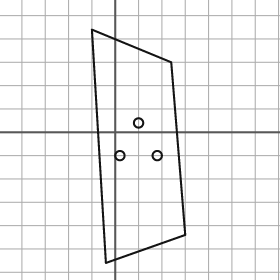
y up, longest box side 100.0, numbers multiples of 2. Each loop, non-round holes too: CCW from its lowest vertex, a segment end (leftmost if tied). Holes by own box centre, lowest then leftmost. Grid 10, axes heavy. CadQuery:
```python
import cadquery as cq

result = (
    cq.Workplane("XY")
    .moveTo(-4.0, -56.0)
    .lineTo(30.0, -44.0)
    .lineTo(24.0, 30.0)
    .lineTo(-10.0, 44.0)
    .close()
    .moveTo(2.0, -10.0)
    .circle(2.0)
    .moveTo(18.0, -10.0)
    .circle(2.0)
    .moveTo(10.0, 4.0)
    .circle(2.0)
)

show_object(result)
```